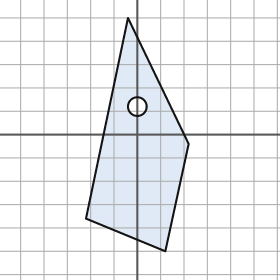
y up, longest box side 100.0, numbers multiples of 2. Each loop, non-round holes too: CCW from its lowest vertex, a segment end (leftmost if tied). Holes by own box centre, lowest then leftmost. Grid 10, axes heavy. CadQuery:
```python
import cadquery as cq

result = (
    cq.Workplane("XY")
    .moveTo(12.0, -50.0)
    .lineTo(22.0, -4.0)
    .lineTo(-4.0, 50.0)
    .lineTo(-22.0, -36.0)
    .close()
    .moveTo(0.0, 12.0)
    .circle(4.0)
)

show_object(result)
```